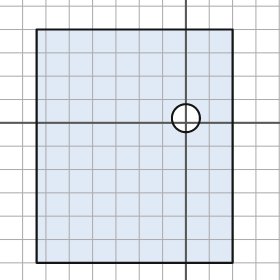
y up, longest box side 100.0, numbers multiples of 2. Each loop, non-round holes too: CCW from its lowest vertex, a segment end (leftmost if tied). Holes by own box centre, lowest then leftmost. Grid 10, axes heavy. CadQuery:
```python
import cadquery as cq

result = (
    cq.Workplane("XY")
    .moveTo(-64.0, -60.0)
    .lineTo(20.0, -60.0)
    .lineTo(20.0, 40.0)
    .lineTo(-64.0, 40.0)
    .close()
    .moveTo(0.0, 2.0)
    .circle(6.0)
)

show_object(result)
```